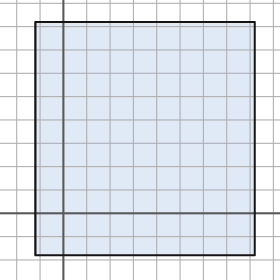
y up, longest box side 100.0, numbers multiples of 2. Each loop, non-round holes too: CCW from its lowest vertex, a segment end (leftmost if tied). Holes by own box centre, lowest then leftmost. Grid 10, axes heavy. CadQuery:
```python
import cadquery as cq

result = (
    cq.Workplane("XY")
    .moveTo(-12.0, -18.0)
    .lineTo(82.0, -18.0)
    .lineTo(82.0, 82.0)
    .lineTo(-12.0, 82.0)
    .close()
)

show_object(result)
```